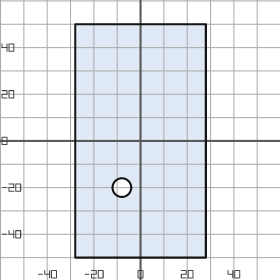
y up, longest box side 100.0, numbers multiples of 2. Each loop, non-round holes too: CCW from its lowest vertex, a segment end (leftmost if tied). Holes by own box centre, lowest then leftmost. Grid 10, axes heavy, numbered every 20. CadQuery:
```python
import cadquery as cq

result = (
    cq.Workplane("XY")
    .moveTo(-28.0, -50.0)
    .lineTo(28.0, -50.0)
    .lineTo(28.0, 50.0)
    .lineTo(-28.0, 50.0)
    .close()
    .moveTo(-8.0, -20.0)
    .circle(4.0)
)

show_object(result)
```